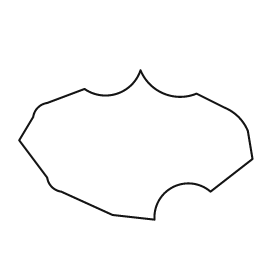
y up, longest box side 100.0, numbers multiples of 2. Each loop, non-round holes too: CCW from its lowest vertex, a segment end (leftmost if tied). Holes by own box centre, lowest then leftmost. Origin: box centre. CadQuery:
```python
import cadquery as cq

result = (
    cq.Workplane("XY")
    .moveTo(8.0, -32.0)
    .threePointArc((16.0, -18.0), (32.0, -20.0))
    .lineTo(50.0, -6.0)
    .lineTo(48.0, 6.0)
    .threePointArc((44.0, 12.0), (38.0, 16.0))
    .lineTo(26.0, 22.0)
    .threePointArc((12.0, 22.0), (2.0, 32.0))
    .threePointArc((-8.0, 22.0), (-22.0, 24.0))
    .lineTo(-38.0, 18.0)
    .threePointArc((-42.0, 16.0), (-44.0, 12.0))
    .lineTo(-50.0, 2.0)
    .lineTo(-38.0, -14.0)
    .threePointArc((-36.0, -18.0), (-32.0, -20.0))
    .lineTo(-10.0, -30.0)
    .close()
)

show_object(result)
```